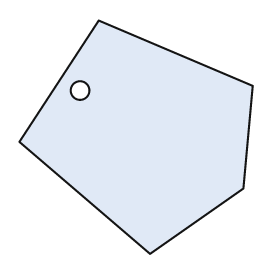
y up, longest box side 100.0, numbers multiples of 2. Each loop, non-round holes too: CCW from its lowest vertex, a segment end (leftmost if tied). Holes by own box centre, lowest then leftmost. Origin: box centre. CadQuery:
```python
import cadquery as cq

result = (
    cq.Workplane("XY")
    .moveTo(6.0, -50.0)
    .lineTo(46.0, -22.0)
    .lineTo(50.0, 22.0)
    .lineTo(-16.0, 50.0)
    .lineTo(-50.0, -2.0)
    .close()
    .moveTo(-24.0, 20.0)
    .circle(4.0)
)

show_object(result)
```